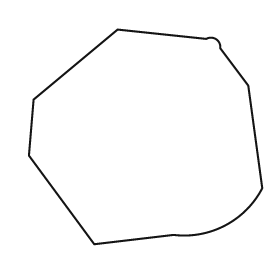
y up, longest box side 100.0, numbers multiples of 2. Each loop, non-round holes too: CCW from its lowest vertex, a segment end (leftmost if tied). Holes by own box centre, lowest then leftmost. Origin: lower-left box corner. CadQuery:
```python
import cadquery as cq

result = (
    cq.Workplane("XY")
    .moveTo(28.0, 0.0)
    .lineTo(62.0, 4.0)
    .threePointArc((84.0, 8.0), (100.0, 24.0))
    .lineTo(94.0, 68.0)
    .lineTo(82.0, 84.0)
    .threePointArc((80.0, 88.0), (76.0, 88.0))
    .lineTo(38.0, 92.0)
    .lineTo(2.0, 62.0)
    .lineTo(0.0, 38.0)
    .close()
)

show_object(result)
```